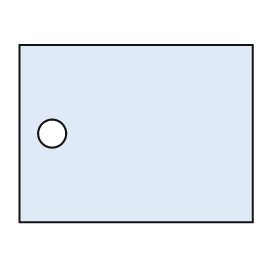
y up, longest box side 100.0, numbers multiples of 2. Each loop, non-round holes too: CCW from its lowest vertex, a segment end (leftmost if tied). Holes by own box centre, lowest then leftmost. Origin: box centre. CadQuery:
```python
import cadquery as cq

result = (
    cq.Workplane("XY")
    .moveTo(-50.0, -38.0)
    .lineTo(50.0, -38.0)
    .lineTo(50.0, 38.0)
    .lineTo(-50.0, 38.0)
    .close()
    .moveTo(-36.0, 0.0)
    .circle(6.0)
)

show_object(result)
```